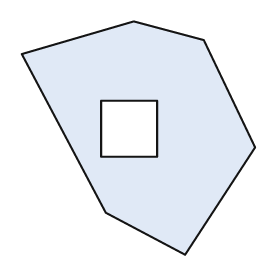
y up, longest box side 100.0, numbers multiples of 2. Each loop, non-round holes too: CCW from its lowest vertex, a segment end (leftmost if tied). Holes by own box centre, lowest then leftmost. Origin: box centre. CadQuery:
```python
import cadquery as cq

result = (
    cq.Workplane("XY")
    .moveTo(20.0, -50.0)
    .lineTo(50.0, -4.0)
    .lineTo(28.0, 42.0)
    .lineTo(-2.0, 50.0)
    .lineTo(-50.0, 36.0)
    .lineTo(-14.0, -32.0)
    .close()
    .moveTo(-16.0, -8.0)
    .lineTo(8.0, -8.0)
    .lineTo(8.0, 16.0)
    .lineTo(-16.0, 16.0)
    .close()
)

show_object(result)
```